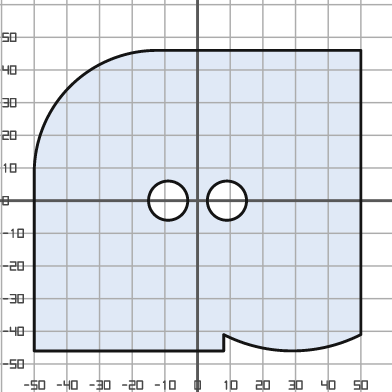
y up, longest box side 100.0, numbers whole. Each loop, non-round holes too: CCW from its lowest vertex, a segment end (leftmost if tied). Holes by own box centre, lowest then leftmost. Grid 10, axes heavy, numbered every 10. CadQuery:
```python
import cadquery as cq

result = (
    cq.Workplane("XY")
    .moveTo(-50.0, -46.0)
    .lineTo(8.0, -46.0)
    .lineTo(8.0, -41.0)
    .threePointArc((29.0, -46.0), (50.0, -41.0))
    .lineTo(50.0, 46.0)
    .lineTo(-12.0, 46.0)
    .threePointArc((-39.0, 35.0), (-50.0, 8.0))
    .close()
    .moveTo(-9.0, 0.0)
    .circle(6.0)
    .moveTo(9.0, 0.0)
    .circle(6.0)
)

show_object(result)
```